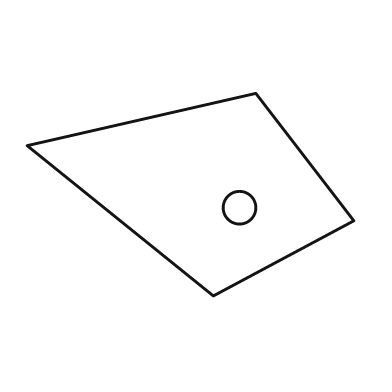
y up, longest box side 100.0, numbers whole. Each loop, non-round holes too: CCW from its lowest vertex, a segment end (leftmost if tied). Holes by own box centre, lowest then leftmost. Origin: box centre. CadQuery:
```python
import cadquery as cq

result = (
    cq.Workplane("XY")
    .moveTo(7.0, -31.0)
    .lineTo(50.0, -8.0)
    .lineTo(20.0, 31.0)
    .lineTo(-50.0, 15.0)
    .close()
    .moveTo(15.0, -4.0)
    .circle(5.0)
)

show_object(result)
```